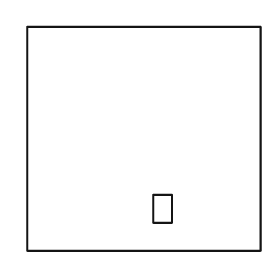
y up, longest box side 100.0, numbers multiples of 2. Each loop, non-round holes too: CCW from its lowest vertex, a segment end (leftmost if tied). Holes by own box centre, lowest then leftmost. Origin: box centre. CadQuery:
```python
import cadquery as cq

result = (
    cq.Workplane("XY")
    .moveTo(-50.0, -48.0)
    .lineTo(50.0, -48.0)
    .lineTo(50.0, 48.0)
    .lineTo(-50.0, 48.0)
    .close()
    .moveTo(4.0, -36.0)
    .lineTo(12.0, -36.0)
    .lineTo(12.0, -24.0)
    .lineTo(4.0, -24.0)
    .close()
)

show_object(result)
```